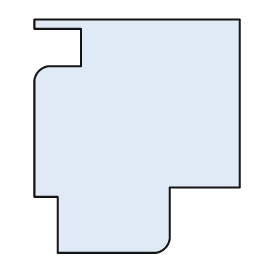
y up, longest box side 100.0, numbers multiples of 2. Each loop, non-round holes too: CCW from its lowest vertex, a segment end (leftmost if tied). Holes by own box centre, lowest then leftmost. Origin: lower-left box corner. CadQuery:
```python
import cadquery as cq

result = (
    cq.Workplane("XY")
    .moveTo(10.0, 0.0)
    .lineTo(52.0, 0.0)
    .threePointArc((56.0, 2.0), (58.0, 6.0))
    .lineTo(58.0, 28.0)
    .lineTo(88.0, 28.0)
    .lineTo(88.0, 100.0)
    .lineTo(0.0, 100.0)
    .lineTo(0.0, 96.0)
    .lineTo(20.0, 96.0)
    .lineTo(20.0, 80.0)
    .lineTo(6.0, 80.0)
    .threePointArc((2.0, 78.0), (0.0, 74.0))
    .lineTo(0.0, 24.0)
    .lineTo(10.0, 24.0)
    .close()
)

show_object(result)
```